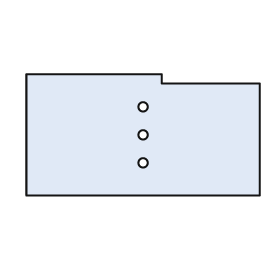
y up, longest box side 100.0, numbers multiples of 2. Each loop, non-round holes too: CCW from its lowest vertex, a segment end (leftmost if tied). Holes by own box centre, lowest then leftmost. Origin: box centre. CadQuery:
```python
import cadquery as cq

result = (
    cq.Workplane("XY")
    .moveTo(-50.0, -26.0)
    .lineTo(50.0, -26.0)
    .lineTo(50.0, 22.0)
    .lineTo(8.0, 22.0)
    .lineTo(8.0, 26.0)
    .lineTo(-50.0, 26.0)
    .close()
    .moveTo(0.0, -12.0)
    .circle(2.0)
    .moveTo(0.0, 0.0)
    .circle(2.0)
    .moveTo(0.0, 12.0)
    .circle(2.0)
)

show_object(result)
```